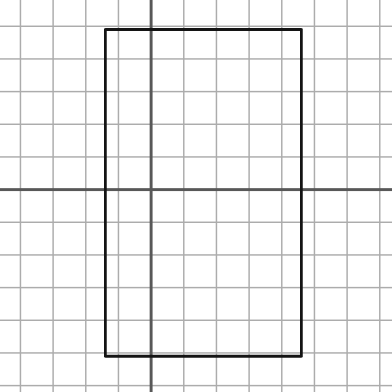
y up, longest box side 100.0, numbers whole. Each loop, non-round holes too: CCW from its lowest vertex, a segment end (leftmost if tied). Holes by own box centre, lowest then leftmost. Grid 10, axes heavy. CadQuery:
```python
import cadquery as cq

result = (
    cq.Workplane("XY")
    .moveTo(-14.0, -51.0)
    .lineTo(46.0, -51.0)
    .lineTo(46.0, 49.0)
    .lineTo(-14.0, 49.0)
    .close()
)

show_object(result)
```